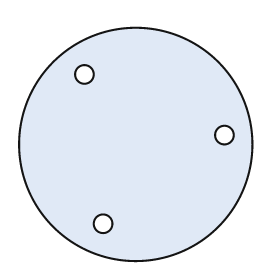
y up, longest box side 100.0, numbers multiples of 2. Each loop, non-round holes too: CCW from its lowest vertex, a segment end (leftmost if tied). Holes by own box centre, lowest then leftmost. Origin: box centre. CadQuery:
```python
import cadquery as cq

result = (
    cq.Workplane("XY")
    .moveTo(0.0, 0.0)
    .circle(50.0)
    .moveTo(-14.0, -34.0)
    .circle(4.0)
    .moveTo(38.0, 4.0)
    .circle(4.0)
    .moveTo(-22.0, 30.0)
    .circle(4.0)
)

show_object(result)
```